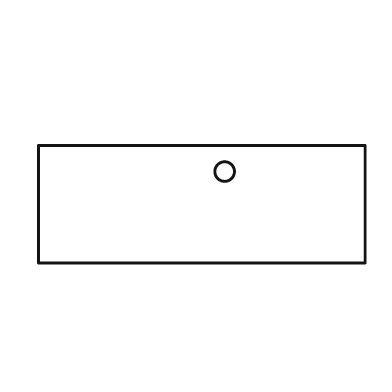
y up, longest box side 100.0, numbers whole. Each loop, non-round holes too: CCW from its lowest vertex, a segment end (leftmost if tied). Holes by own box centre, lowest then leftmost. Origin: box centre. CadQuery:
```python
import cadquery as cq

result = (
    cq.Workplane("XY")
    .moveTo(-50.0, -18.0)
    .lineTo(50.0, -18.0)
    .lineTo(50.0, 18.0)
    .lineTo(-50.0, 18.0)
    .close()
    .moveTo(7.0, 10.0)
    .circle(3.0)
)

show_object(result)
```